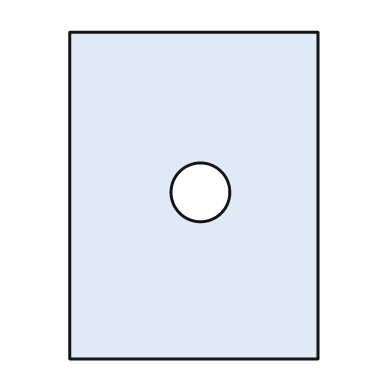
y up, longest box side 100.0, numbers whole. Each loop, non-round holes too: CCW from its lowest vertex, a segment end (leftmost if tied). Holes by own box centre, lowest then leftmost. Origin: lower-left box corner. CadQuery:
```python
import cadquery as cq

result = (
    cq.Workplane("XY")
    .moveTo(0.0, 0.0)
    .lineTo(76.0, 0.0)
    .lineTo(76.0, 100.0)
    .lineTo(0.0, 100.0)
    .close()
    .moveTo(40.0, 51.0)
    .circle(9.0)
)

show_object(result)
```